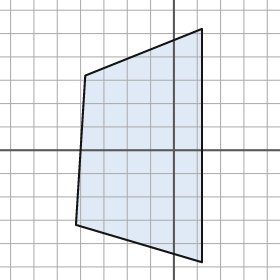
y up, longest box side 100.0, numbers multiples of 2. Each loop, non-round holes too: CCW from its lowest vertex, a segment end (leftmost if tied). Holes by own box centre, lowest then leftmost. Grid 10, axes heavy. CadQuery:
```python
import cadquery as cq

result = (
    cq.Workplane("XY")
    .moveTo(12.0, -48.0)
    .lineTo(12.0, 52.0)
    .lineTo(-38.0, 32.0)
    .lineTo(-42.0, -32.0)
    .close()
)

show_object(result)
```